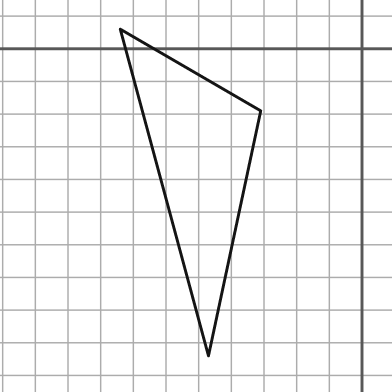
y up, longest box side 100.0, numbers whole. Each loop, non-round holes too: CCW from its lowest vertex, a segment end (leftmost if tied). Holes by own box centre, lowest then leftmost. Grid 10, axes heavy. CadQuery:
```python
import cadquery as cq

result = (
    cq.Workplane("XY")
    .moveTo(-47.0, -94.0)
    .lineTo(-31.0, -19.0)
    .lineTo(-74.0, 6.0)
    .close()
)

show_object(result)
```